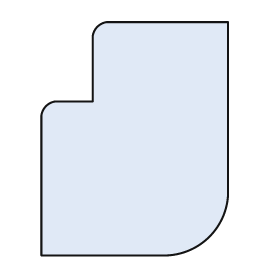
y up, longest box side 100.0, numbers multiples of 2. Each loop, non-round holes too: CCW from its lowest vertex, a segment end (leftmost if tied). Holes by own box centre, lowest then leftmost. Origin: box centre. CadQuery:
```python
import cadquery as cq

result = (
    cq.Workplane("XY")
    .moveTo(-40.0, -50.0)
    .lineTo(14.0, -50.0)
    .threePointArc((32.0, -42.0), (40.0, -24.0))
    .lineTo(40.0, 50.0)
    .lineTo(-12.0, 50.0)
    .threePointArc((-16.0, 48.0), (-18.0, 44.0))
    .lineTo(-18.0, 16.0)
    .lineTo(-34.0, 16.0)
    .threePointArc((-38.0, 14.0), (-40.0, 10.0))
    .close()
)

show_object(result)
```